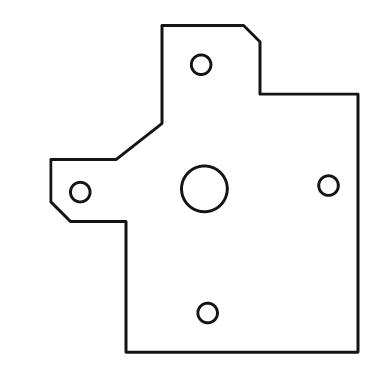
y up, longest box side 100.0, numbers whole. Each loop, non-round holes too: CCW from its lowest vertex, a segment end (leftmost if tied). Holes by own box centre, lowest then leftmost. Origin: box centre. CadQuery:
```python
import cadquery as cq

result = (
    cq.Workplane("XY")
    .moveTo(-24.0, -50.0)
    .lineTo(47.0, -50.0)
    .lineTo(47.0, 29.0)
    .lineTo(17.0, 29.0)
    .lineTo(17.0, 45.0)
    .lineTo(12.0, 50.0)
    .lineTo(-13.0, 50.0)
    .lineTo(-13.0, 20.0)
    .lineTo(-27.0, 9.0)
    .lineTo(-47.0, 9.0)
    .lineTo(-47.0, -4.0)
    .lineTo(-41.0, -10.0)
    .lineTo(-24.0, -10.0)
    .close()
    .moveTo(1.0, -38.0)
    .circle(3.0)
    .moveTo(-38.0, -1.0)
    .circle(3.0)
    .moveTo(0.0, 0.0)
    .circle(7.0)
    .moveTo(38.0, 1.0)
    .circle(3.0)
    .moveTo(-1.0, 38.0)
    .circle(3.0)
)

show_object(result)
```